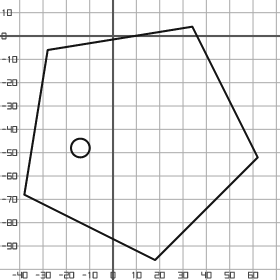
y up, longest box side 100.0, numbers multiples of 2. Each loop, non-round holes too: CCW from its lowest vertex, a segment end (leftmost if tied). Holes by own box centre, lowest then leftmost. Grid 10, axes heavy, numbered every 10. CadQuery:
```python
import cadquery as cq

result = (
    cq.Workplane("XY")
    .moveTo(18.0, -96.0)
    .lineTo(62.0, -52.0)
    .lineTo(34.0, 4.0)
    .lineTo(-28.0, -6.0)
    .lineTo(-38.0, -68.0)
    .close()
    .moveTo(-14.0, -48.0)
    .circle(4.0)
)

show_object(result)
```